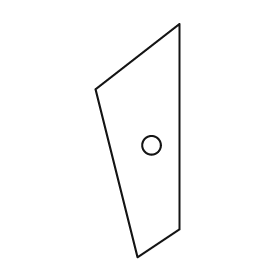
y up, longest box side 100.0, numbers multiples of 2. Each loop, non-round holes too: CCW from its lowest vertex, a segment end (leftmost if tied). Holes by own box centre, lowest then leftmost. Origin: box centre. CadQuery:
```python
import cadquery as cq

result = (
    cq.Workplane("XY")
    .moveTo(0.0, -50.0)
    .lineTo(18.0, -38.0)
    .lineTo(18.0, 50.0)
    .lineTo(-18.0, 22.0)
    .close()
    .moveTo(6.0, -2.0)
    .circle(4.0)
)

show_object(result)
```